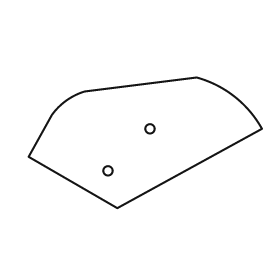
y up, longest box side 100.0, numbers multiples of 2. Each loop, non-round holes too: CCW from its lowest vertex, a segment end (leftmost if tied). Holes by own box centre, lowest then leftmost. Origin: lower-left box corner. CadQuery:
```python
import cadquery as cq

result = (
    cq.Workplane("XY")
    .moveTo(38.0, 0.0)
    .lineTo(100.0, 34.0)
    .threePointArc((88.0, 48.0), (72.0, 56.0))
    .lineTo(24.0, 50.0)
    .threePointArc((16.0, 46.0), (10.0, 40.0))
    .lineTo(0.0, 22.0)
    .close()
    .moveTo(34.0, 16.0)
    .circle(2.0)
    .moveTo(52.0, 34.0)
    .circle(2.0)
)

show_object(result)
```